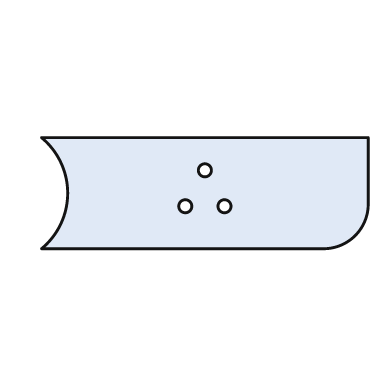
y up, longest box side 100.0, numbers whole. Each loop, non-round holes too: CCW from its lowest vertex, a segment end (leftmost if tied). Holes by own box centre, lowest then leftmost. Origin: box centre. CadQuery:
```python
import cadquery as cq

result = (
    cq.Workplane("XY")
    .moveTo(-50.0, -17.0)
    .lineTo(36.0, -17.0)
    .threePointArc((46.0, -13.0), (50.0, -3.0))
    .lineTo(50.0, 17.0)
    .lineTo(-50.0, 17.0)
    .threePointArc((-42.0, 0.0), (-50.0, -17.0))
    .close()
    .moveTo(-6.0, -4.0)
    .circle(2.0)
    .moveTo(6.0, -4.0)
    .circle(2.0)
    .moveTo(0.0, 7.0)
    .circle(2.0)
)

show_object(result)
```